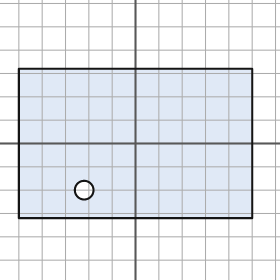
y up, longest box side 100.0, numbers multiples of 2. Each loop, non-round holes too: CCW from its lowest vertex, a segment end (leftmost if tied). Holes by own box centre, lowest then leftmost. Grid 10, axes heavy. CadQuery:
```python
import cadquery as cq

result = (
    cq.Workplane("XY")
    .moveTo(-50.0, -32.0)
    .lineTo(50.0, -32.0)
    .lineTo(50.0, 32.0)
    .lineTo(-50.0, 32.0)
    .close()
    .moveTo(-22.0, -20.0)
    .circle(4.0)
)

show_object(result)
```